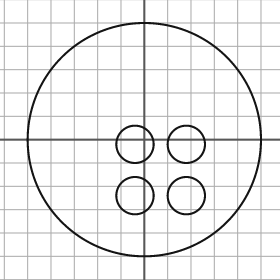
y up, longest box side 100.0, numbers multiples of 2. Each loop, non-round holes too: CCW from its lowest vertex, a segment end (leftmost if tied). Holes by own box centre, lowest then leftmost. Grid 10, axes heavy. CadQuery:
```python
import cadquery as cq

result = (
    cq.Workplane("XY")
    .moveTo(0.0, 0.0)
    .circle(50.0)
    .moveTo(-4.0, -24.0)
    .circle(8.0)
    .moveTo(18.0, -24.0)
    .circle(8.0)
    .moveTo(-4.0, -2.0)
    .circle(8.0)
    .moveTo(18.0, -2.0)
    .circle(8.0)
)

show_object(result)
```